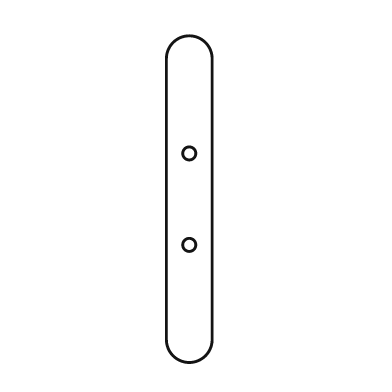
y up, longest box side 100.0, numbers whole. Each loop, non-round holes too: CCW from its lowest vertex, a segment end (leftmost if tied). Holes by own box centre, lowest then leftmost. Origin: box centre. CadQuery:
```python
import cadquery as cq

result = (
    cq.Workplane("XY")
    .moveTo(-7.0, -43.0)
    .threePointArc((0.0, -50.0), (7.0, -43.0))
    .lineTo(7.0, 43.0)
    .threePointArc((0.0, 50.0), (-7.0, 43.0))
    .close()
    .moveTo(0.0, -14.0)
    .circle(2.0)
    .moveTo(0.0, 14.0)
    .circle(2.0)
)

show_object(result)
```